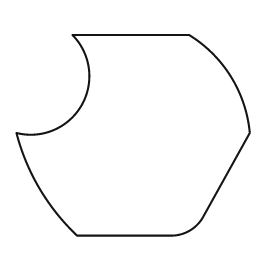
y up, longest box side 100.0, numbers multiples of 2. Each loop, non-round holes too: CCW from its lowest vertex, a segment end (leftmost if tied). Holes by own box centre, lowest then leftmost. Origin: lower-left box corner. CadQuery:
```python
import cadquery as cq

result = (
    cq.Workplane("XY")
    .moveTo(26.0, 0.0)
    .lineTo(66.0, 0.0)
    .threePointArc((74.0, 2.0), (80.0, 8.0))
    .lineTo(100.0, 44.0)
    .threePointArc((92.0, 68.0), (74.0, 86.0))
    .lineTo(24.0, 86.0)
    .threePointArc((28.0, 56.0), (0.0, 44.0))
    .threePointArc((10.0, 20.0), (26.0, 0.0))
    .close()
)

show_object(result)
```